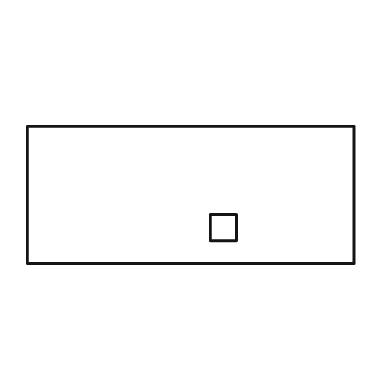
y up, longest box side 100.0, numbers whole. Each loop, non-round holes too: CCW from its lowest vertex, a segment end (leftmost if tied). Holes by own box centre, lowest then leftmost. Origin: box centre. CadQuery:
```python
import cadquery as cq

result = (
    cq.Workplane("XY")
    .moveTo(-50.0, -21.0)
    .lineTo(50.0, -21.0)
    .lineTo(50.0, 21.0)
    .lineTo(-50.0, 21.0)
    .close()
    .moveTo(6.0, -14.0)
    .lineTo(14.0, -14.0)
    .lineTo(14.0, -6.0)
    .lineTo(6.0, -6.0)
    .close()
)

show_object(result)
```